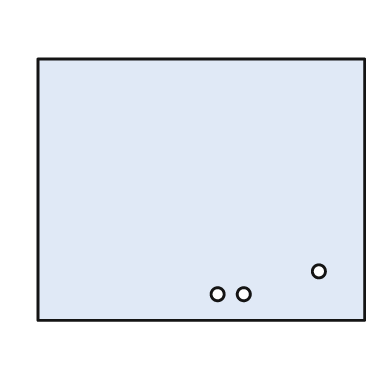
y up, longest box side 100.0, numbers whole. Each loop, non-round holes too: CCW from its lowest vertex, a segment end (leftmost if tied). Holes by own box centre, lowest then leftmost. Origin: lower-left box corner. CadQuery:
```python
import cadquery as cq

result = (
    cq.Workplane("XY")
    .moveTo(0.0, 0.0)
    .lineTo(100.0, 0.0)
    .lineTo(100.0, 80.0)
    .lineTo(0.0, 80.0)
    .close()
    .moveTo(55.0, 8.0)
    .circle(2.0)
    .moveTo(63.0, 8.0)
    .circle(2.0)
    .moveTo(86.0, 15.0)
    .circle(2.0)
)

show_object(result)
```